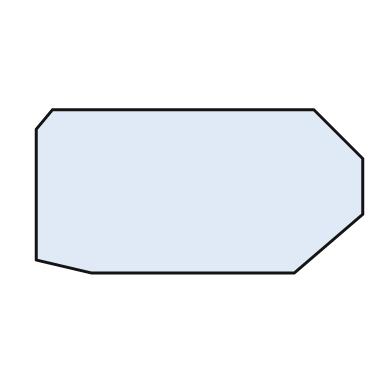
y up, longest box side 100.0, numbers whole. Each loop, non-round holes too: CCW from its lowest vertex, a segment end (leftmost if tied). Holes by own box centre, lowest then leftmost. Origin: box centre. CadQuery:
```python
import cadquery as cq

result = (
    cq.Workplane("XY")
    .moveTo(-33.0, -25.0)
    .lineTo(29.0, -25.0)
    .lineTo(50.0, -7.0)
    .lineTo(50.0, 10.0)
    .lineTo(35.0, 25.0)
    .lineTo(-45.0, 25.0)
    .lineTo(-50.0, 19.0)
    .lineTo(-50.0, -21.0)
    .close()
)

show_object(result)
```